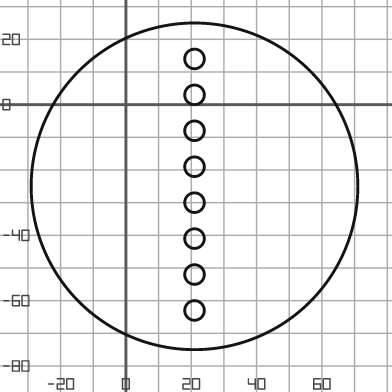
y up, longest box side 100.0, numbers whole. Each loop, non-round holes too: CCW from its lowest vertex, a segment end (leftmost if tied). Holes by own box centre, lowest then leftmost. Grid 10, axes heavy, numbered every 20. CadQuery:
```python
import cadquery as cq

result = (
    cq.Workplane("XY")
    .moveTo(21.0, -25.0)
    .circle(50.0)
    .moveTo(21.0, -63.0)
    .circle(3.0)
    .moveTo(21.0, -52.0)
    .circle(3.0)
    .moveTo(21.0, -41.0)
    .circle(3.0)
    .moveTo(21.0, -30.0)
    .circle(3.0)
    .moveTo(21.0, -19.0)
    .circle(3.0)
    .moveTo(21.0, -8.0)
    .circle(3.0)
    .moveTo(21.0, 3.0)
    .circle(3.0)
    .moveTo(21.0, 14.0)
    .circle(3.0)
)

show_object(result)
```